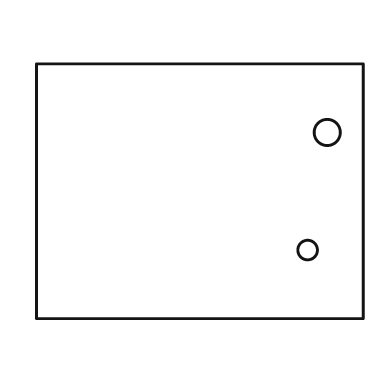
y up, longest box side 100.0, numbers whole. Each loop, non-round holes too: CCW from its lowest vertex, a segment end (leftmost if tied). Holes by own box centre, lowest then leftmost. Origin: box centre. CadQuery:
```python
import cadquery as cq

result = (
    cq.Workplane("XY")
    .moveTo(-50.0, -39.0)
    .lineTo(50.0, -39.0)
    .lineTo(50.0, 39.0)
    .lineTo(-50.0, 39.0)
    .close()
    .moveTo(33.0, -18.0)
    .circle(3.0)
    .moveTo(39.0, 18.0)
    .circle(4.0)
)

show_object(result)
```